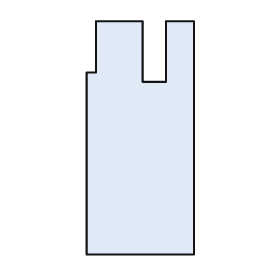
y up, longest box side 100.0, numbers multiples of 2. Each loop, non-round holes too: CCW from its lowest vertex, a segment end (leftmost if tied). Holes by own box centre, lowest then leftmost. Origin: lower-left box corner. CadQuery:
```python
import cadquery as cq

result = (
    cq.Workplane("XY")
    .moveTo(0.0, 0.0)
    .lineTo(46.0, 0.0)
    .lineTo(46.0, 100.0)
    .lineTo(34.0, 100.0)
    .lineTo(34.0, 74.0)
    .lineTo(24.0, 74.0)
    .lineTo(24.0, 100.0)
    .lineTo(4.0, 100.0)
    .lineTo(4.0, 78.0)
    .lineTo(0.0, 78.0)
    .close()
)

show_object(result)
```